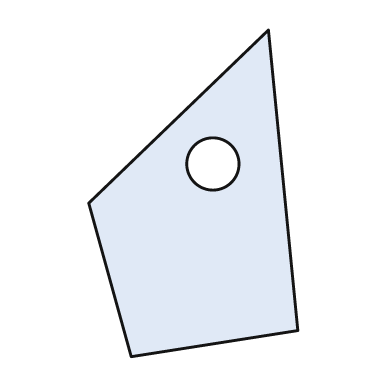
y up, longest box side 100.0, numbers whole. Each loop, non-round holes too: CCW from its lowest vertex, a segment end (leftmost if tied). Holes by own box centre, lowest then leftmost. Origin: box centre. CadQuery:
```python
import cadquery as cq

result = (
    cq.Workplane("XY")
    .moveTo(-19.0, -50.0)
    .lineTo(32.0, -42.0)
    .lineTo(23.0, 50.0)
    .lineTo(-32.0, -3.0)
    .close()
    .moveTo(6.0, 9.0)
    .circle(8.0)
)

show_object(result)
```